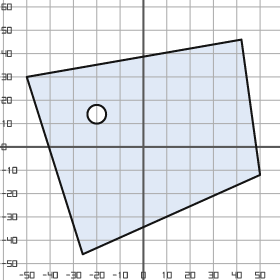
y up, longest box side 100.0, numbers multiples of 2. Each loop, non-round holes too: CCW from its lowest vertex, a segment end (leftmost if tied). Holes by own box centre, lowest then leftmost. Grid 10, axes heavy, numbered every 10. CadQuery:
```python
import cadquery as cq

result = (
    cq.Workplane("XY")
    .moveTo(-26.0, -46.0)
    .lineTo(50.0, -12.0)
    .lineTo(42.0, 46.0)
    .lineTo(-50.0, 30.0)
    .close()
    .moveTo(-20.0, 14.0)
    .circle(4.0)
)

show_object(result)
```